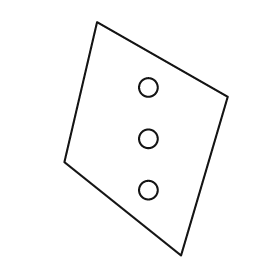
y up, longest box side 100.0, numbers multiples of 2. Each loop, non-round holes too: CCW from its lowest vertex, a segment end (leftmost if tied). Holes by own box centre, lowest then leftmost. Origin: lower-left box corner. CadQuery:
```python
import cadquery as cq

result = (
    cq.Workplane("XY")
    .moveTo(50.0, 0.0)
    .lineTo(70.0, 68.0)
    .lineTo(14.0, 100.0)
    .lineTo(0.0, 40.0)
    .close()
    .moveTo(36.0, 28.0)
    .circle(4.0)
    .moveTo(36.0, 50.0)
    .circle(4.0)
    .moveTo(36.0, 72.0)
    .circle(4.0)
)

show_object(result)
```